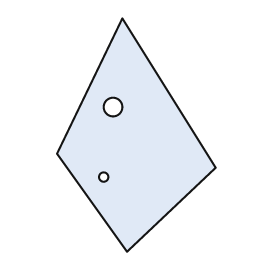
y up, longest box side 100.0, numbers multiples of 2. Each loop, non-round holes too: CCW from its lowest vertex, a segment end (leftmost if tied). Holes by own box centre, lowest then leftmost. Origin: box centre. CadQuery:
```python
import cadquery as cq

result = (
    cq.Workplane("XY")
    .moveTo(-4.0, -50.0)
    .lineTo(34.0, -14.0)
    .lineTo(-6.0, 50.0)
    .lineTo(-34.0, -8.0)
    .close()
    .moveTo(-14.0, -18.0)
    .circle(2.0)
    .moveTo(-10.0, 12.0)
    .circle(4.0)
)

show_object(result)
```